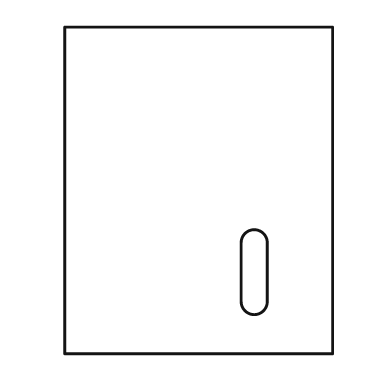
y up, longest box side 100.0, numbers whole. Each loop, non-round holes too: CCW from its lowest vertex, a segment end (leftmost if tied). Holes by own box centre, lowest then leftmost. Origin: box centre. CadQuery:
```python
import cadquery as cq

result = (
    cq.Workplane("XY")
    .moveTo(-41.0, -50.0)
    .lineTo(41.0, -50.0)
    .lineTo(41.0, 50.0)
    .lineTo(-41.0, 50.0)
    .close()
    .moveTo(13.0, -34.0)
    .threePointArc((17.0, -38.0), (21.0, -34.0))
    .lineTo(21.0, -16.0)
    .threePointArc((17.0, -12.0), (13.0, -16.0))
    .close()
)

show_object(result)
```